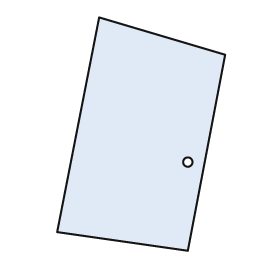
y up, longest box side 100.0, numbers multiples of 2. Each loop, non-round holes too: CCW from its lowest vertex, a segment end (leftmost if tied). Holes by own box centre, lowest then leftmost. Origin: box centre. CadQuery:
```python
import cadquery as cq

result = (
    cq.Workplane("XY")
    .moveTo(20.0, -50.0)
    .lineTo(36.0, 34.0)
    .lineTo(-18.0, 50.0)
    .lineTo(-36.0, -42.0)
    .close()
    .moveTo(20.0, -12.0)
    .circle(2.0)
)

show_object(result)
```